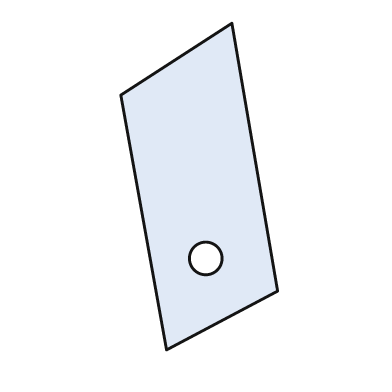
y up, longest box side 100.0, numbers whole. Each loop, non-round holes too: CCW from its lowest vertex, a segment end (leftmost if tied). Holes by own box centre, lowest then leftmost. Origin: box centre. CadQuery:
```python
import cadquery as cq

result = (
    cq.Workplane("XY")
    .moveTo(-10.0, -50.0)
    .lineTo(24.0, -32.0)
    .lineTo(10.0, 50.0)
    .lineTo(-24.0, 28.0)
    .close()
    .moveTo(2.0, -22.0)
    .circle(5.0)
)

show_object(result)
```